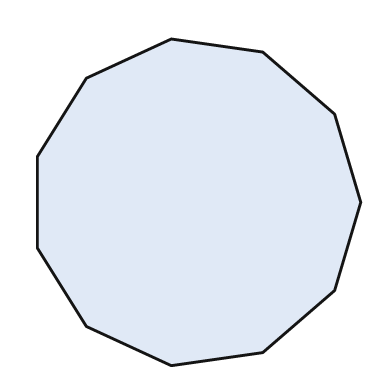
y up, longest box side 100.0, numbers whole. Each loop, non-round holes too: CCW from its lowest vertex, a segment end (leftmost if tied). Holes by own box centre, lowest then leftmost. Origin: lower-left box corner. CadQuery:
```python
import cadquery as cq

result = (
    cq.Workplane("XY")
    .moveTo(41.0, 0.0)
    .lineTo(69.0, 4.0)
    .lineTo(91.0, 23.0)
    .lineTo(99.0, 50.0)
    .lineTo(91.0, 77.0)
    .lineTo(69.0, 96.0)
    .lineTo(41.0, 100.0)
    .lineTo(15.0, 88.0)
    .lineTo(0.0, 64.0)
    .lineTo(0.0, 36.0)
    .lineTo(15.0, 12.0)
    .close()
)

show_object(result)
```